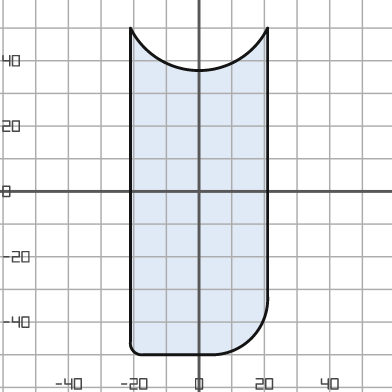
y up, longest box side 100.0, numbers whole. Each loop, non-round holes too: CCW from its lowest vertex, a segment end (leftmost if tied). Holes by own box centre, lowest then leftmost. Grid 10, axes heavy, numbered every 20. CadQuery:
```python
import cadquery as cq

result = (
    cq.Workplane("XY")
    .moveTo(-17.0, -50.0)
    .lineTo(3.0, -50.0)
    .threePointArc((16.0, -45.0), (21.0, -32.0))
    .lineTo(21.0, 50.0)
    .threePointArc((0.0, 37.0), (-21.0, 50.0))
    .lineTo(-21.0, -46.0)
    .threePointArc((-20.0, -49.0), (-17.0, -50.0))
    .close()
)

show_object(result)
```